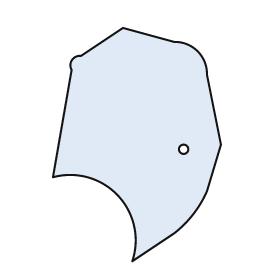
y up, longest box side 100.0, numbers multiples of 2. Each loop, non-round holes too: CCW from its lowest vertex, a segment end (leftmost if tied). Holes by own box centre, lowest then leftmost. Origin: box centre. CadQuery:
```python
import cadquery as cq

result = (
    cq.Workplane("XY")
    .moveTo(-2.0, -50.0)
    .lineTo(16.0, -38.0)
    .threePointArc((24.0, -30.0), (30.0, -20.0))
    .lineTo(36.0, 0.0)
    .lineTo(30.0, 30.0)
    .threePointArc((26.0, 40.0), (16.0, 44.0))
    .lineTo(-6.0, 50.0)
    .lineTo(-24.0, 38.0)
    .threePointArc((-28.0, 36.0), (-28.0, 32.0))
    .lineTo(-36.0, -14.0)
    .threePointArc((-8.0, -22.0), (-2.0, -50.0))
    .close()
    .moveTo(20.0, -2.0)
    .circle(2.0)
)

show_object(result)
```